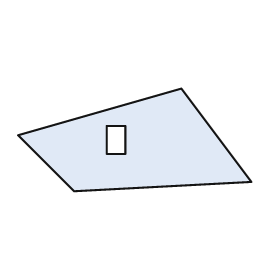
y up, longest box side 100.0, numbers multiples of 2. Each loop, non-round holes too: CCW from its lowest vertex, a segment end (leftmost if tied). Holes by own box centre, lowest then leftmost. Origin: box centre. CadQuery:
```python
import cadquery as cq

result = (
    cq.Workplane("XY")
    .moveTo(-26.0, -22.0)
    .lineTo(50.0, -18.0)
    .lineTo(20.0, 22.0)
    .lineTo(-50.0, 2.0)
    .close()
    .moveTo(-12.0, -6.0)
    .lineTo(-4.0, -6.0)
    .lineTo(-4.0, 6.0)
    .lineTo(-12.0, 6.0)
    .close()
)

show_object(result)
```